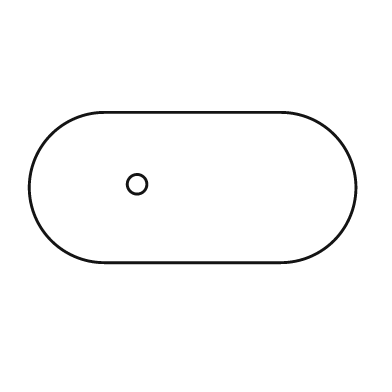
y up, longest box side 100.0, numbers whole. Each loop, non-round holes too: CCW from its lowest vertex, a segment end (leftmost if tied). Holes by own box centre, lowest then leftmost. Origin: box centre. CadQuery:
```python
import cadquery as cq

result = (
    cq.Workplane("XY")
    .moveTo(-27.0, -23.0)
    .lineTo(27.0, -23.0)
    .threePointArc((50.0, 0.0), (27.0, 23.0))
    .lineTo(-27.0, 23.0)
    .threePointArc((-50.0, 0.0), (-27.0, -23.0))
    .close()
    .moveTo(-17.0, 1.0)
    .circle(3.0)
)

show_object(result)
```